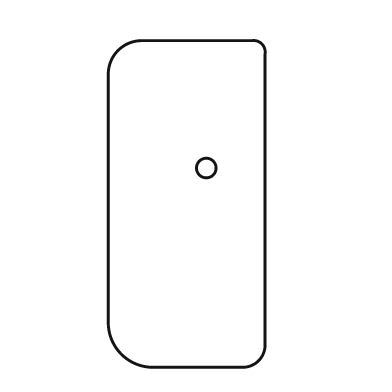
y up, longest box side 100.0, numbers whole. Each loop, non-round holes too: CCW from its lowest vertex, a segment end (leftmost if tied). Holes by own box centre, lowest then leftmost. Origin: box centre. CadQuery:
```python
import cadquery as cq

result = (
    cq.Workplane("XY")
    .moveTo(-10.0, -50.0)
    .lineTo(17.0, -50.0)
    .threePointArc((22.0, -48.0), (24.0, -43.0))
    .lineTo(24.0, 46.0)
    .threePointArc((23.0, 49.0), (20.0, 50.0))
    .lineTo(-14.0, 50.0)
    .threePointArc((-21.0, 47.0), (-24.0, 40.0))
    .lineTo(-24.0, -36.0)
    .threePointArc((-20.0, -46.0), (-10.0, -50.0))
    .close()
    .moveTo(6.0, 11.0)
    .circle(3.0)
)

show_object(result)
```